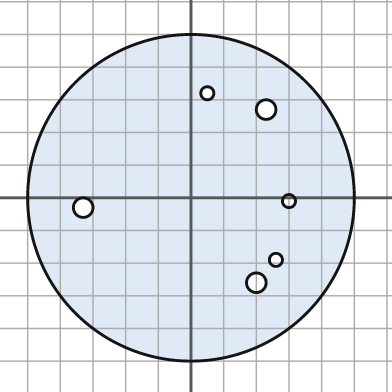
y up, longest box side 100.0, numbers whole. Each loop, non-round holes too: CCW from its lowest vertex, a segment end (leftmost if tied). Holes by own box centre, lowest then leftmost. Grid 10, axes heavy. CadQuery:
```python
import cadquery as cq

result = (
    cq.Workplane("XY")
    .moveTo(0.0, 0.0)
    .circle(50.0)
    .moveTo(20.0, -26.0)
    .circle(3.0)
    .moveTo(26.0, -19.0)
    .circle(2.0)
    .moveTo(-33.0, -3.0)
    .circle(3.0)
    .moveTo(30.0, -1.0)
    .circle(2.0)
    .moveTo(23.0, 27.0)
    .circle(3.0)
    .moveTo(5.0, 32.0)
    .circle(2.0)
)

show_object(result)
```